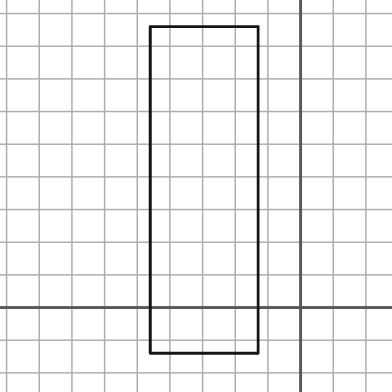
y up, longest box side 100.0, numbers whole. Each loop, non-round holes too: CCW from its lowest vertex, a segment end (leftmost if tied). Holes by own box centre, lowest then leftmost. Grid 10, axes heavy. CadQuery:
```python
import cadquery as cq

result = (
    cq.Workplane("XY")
    .moveTo(-46.0, -14.0)
    .lineTo(-13.0, -14.0)
    .lineTo(-13.0, 86.0)
    .lineTo(-46.0, 86.0)
    .close()
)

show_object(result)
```